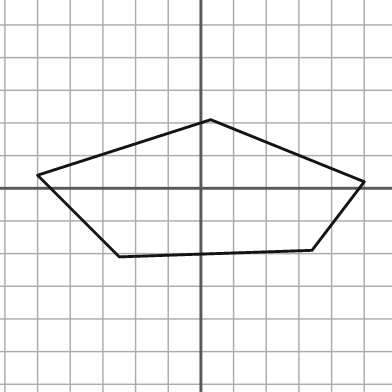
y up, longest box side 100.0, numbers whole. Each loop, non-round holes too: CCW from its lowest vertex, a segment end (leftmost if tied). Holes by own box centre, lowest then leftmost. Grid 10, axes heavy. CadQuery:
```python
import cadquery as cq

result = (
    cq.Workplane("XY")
    .moveTo(-25.0, -21.0)
    .lineTo(34.0, -19.0)
    .lineTo(50.0, 2.0)
    .lineTo(3.0, 21.0)
    .lineTo(-50.0, 4.0)
    .close()
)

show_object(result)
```